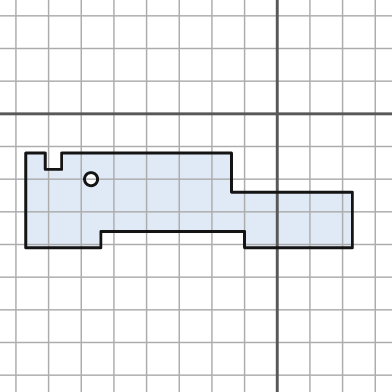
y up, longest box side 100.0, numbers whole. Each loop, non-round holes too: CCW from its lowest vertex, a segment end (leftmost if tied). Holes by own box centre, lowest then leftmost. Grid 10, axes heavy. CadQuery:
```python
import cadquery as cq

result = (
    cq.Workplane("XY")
    .moveTo(-77.0, -41.0)
    .lineTo(-54.0, -41.0)
    .lineTo(-54.0, -36.0)
    .lineTo(-10.0, -36.0)
    .lineTo(-10.0, -41.0)
    .lineTo(23.0, -41.0)
    .lineTo(23.0, -24.0)
    .lineTo(-14.0, -24.0)
    .lineTo(-14.0, -12.0)
    .lineTo(-66.0, -12.0)
    .lineTo(-66.0, -17.0)
    .lineTo(-71.0, -17.0)
    .lineTo(-71.0, -12.0)
    .lineTo(-77.0, -12.0)
    .close()
    .moveTo(-57.0, -20.0)
    .circle(2.0)
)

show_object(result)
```